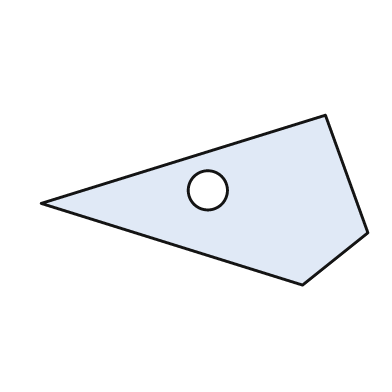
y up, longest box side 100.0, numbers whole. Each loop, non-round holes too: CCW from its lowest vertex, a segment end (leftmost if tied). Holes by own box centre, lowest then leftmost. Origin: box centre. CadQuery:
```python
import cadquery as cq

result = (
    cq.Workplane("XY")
    .moveTo(30.0, -26.0)
    .lineTo(50.0, -10.0)
    .lineTo(37.0, 26.0)
    .lineTo(-50.0, -1.0)
    .close()
    .moveTo(1.0, 3.0)
    .circle(6.0)
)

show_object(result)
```